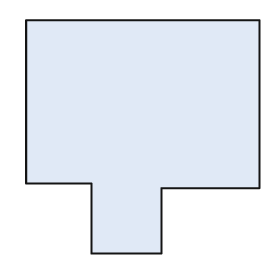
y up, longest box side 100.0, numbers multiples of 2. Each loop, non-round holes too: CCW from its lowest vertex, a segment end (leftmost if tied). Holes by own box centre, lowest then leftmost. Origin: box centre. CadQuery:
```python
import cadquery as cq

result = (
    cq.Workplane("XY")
    .moveTo(-22.0, -50.0)
    .lineTo(8.0, -50.0)
    .lineTo(8.0, -22.0)
    .lineTo(50.0, -22.0)
    .lineTo(50.0, 50.0)
    .lineTo(-50.0, 50.0)
    .lineTo(-50.0, -20.0)
    .lineTo(-22.0, -20.0)
    .close()
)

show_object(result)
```